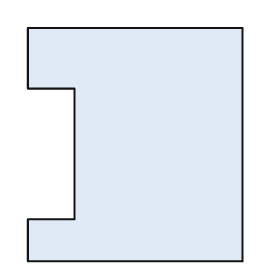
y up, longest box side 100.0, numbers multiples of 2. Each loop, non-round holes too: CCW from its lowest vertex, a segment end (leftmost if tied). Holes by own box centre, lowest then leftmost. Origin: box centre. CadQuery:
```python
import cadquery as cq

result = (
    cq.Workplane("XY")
    .moveTo(-46.0, -50.0)
    .lineTo(46.0, -50.0)
    .lineTo(46.0, 50.0)
    .lineTo(-46.0, 50.0)
    .lineTo(-46.0, 24.0)
    .lineTo(-26.0, 24.0)
    .lineTo(-26.0, -32.0)
    .lineTo(-46.0, -32.0)
    .close()
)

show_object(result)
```